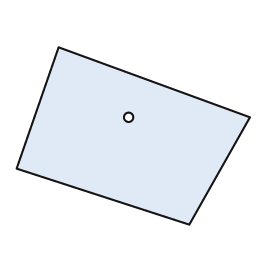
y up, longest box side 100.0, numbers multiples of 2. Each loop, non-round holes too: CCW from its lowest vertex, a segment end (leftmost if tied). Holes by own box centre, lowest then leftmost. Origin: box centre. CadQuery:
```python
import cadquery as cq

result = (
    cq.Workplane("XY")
    .moveTo(24.0, -38.0)
    .lineTo(50.0, 8.0)
    .lineTo(-32.0, 38.0)
    .lineTo(-50.0, -14.0)
    .close()
    .moveTo(-2.0, 8.0)
    .circle(2.0)
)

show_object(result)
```